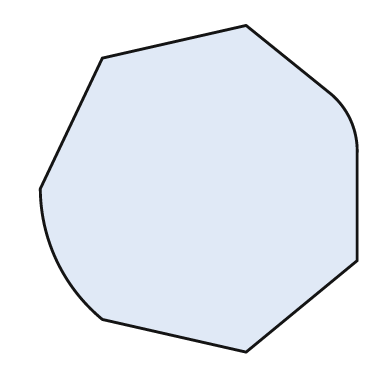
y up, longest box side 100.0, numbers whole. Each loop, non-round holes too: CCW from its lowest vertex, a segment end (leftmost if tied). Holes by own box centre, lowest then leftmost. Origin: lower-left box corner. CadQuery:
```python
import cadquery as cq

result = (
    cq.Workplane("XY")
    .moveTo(63.0, 0.0)
    .lineTo(97.0, 28.0)
    .lineTo(97.0, 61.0)
    .threePointArc((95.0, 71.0), (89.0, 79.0))
    .lineTo(63.0, 100.0)
    .lineTo(19.0, 90.0)
    .lineTo(0.0, 50.0)
    .threePointArc((5.0, 28.0), (19.0, 10.0))
    .close()
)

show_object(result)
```